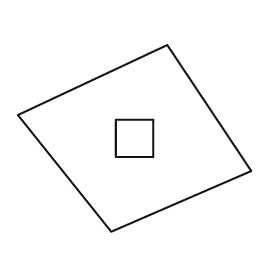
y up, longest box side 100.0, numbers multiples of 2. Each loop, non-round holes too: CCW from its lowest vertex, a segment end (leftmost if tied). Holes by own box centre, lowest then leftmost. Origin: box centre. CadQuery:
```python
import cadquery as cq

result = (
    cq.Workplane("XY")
    .moveTo(-10.0, -40.0)
    .lineTo(50.0, -14.0)
    .lineTo(14.0, 40.0)
    .lineTo(-50.0, 10.0)
    .close()
    .moveTo(-8.0, -8.0)
    .lineTo(8.0, -8.0)
    .lineTo(8.0, 8.0)
    .lineTo(-8.0, 8.0)
    .close()
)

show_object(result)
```